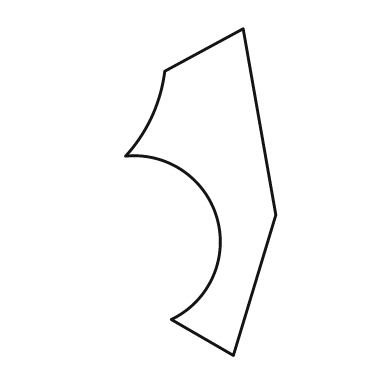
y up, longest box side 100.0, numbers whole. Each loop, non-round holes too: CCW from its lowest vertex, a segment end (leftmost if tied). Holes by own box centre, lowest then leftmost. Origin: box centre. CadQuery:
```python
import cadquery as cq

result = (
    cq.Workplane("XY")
    .moveTo(10.0, -50.0)
    .lineTo(23.0, -7.0)
    .lineTo(13.0, 50.0)
    .lineTo(-11.0, 37.0)
    .threePointArc((-15.0, 23.0), (-23.0, 11.0))
    .threePointArc((5.0, -8.0), (-9.0, -39.0))
    .close()
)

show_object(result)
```